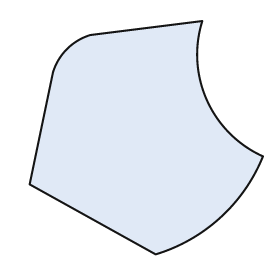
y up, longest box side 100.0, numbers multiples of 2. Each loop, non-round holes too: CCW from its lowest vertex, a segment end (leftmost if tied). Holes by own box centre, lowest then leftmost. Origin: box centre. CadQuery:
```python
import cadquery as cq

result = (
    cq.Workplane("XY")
    .moveTo(4.0, -50.0)
    .threePointArc((32.0, -34.0), (50.0, -8.0))
    .threePointArc((26.0, 16.0), (24.0, 50.0))
    .lineTo(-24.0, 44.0)
    .threePointArc((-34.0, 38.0), (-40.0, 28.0))
    .lineTo(-50.0, -20.0)
    .close()
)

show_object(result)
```